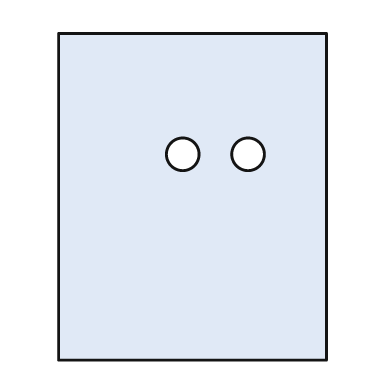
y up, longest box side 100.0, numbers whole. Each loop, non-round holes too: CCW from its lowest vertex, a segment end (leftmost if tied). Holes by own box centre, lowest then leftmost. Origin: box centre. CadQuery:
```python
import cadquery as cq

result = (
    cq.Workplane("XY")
    .moveTo(-41.0, -50.0)
    .lineTo(41.0, -50.0)
    .lineTo(41.0, 50.0)
    .lineTo(-41.0, 50.0)
    .close()
    .moveTo(-3.0, 13.0)
    .circle(5.0)
    .moveTo(17.0, 13.0)
    .circle(5.0)
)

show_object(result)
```